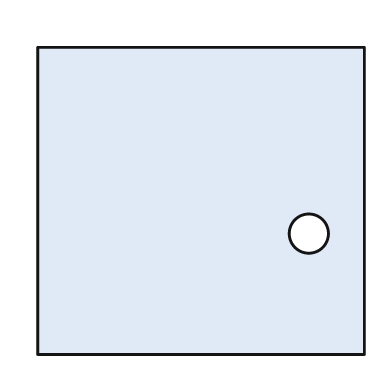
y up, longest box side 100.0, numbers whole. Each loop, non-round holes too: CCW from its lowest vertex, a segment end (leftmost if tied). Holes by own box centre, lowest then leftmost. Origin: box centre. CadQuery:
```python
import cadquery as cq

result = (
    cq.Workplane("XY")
    .moveTo(-50.0, -47.0)
    .lineTo(50.0, -47.0)
    .lineTo(50.0, 47.0)
    .lineTo(-50.0, 47.0)
    .close()
    .moveTo(33.0, -10.0)
    .circle(6.0)
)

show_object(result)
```